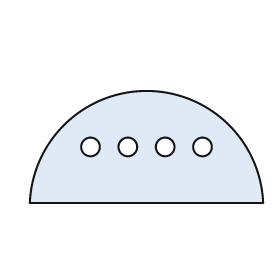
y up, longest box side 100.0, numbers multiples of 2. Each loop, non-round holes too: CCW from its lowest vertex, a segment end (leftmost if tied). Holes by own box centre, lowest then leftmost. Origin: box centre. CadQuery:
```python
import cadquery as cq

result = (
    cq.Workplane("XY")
    .moveTo(-50.0, -24.0)
    .lineTo(50.0, -24.0)
    .threePointArc((0.0, 24.0), (-50.0, -24.0))
    .close()
    .moveTo(-24.0, 0.0)
    .circle(4.0)
    .moveTo(-8.0, 0.0)
    .circle(4.0)
    .moveTo(8.0, 0.0)
    .circle(4.0)
    .moveTo(24.0, 0.0)
    .circle(4.0)
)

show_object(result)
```